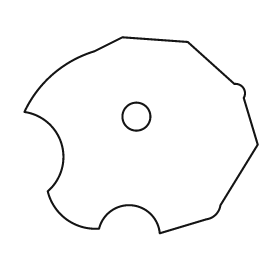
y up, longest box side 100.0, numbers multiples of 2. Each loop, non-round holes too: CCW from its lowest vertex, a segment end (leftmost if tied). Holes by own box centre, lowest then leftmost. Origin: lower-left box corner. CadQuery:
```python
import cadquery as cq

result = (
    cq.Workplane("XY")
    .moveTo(58.0, 0.0)
    .lineTo(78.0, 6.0)
    .threePointArc((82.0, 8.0), (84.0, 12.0))
    .lineTo(100.0, 38.0)
    .lineTo(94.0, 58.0)
    .threePointArc((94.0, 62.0), (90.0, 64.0))
    .lineTo(70.0, 82.0)
    .lineTo(42.0, 84.0)
    .lineTo(30.0, 78.0)
    .threePointArc((12.0, 68.0), (0.0, 52.0))
    .threePointArc((16.0, 38.0), (10.0, 18.0))
    .threePointArc((18.0, 6.0), (32.0, 2.0))
    .threePointArc((46.0, 12.0), (58.0, 0.0))
    .close()
    .moveTo(48.0, 50.0)
    .circle(6.0)
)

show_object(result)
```